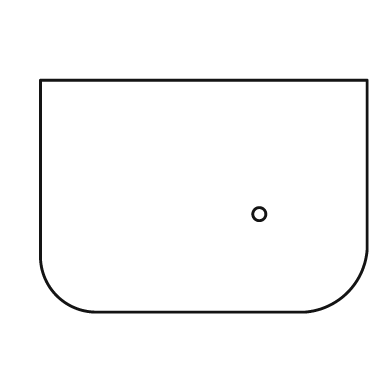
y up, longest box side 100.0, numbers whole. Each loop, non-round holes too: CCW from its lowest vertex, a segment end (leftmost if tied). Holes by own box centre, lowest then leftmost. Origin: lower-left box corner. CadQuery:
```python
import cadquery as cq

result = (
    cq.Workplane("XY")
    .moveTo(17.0, 0.0)
    .lineTo(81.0, 0.0)
    .threePointArc((94.0, 6.0), (100.0, 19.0))
    .lineTo(100.0, 71.0)
    .lineTo(0.0, 71.0)
    .lineTo(0.0, 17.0)
    .threePointArc((5.0, 5.0), (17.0, 0.0))
    .close()
    .moveTo(67.0, 30.0)
    .circle(2.0)
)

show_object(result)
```